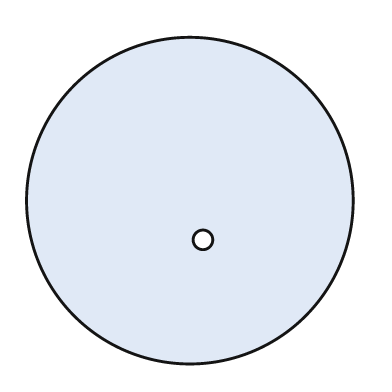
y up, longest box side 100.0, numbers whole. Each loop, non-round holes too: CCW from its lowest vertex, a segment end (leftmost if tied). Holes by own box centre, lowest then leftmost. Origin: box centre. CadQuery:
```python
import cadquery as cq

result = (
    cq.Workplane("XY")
    .moveTo(0.0, 0.0)
    .circle(50.0)
    .moveTo(4.0, -12.0)
    .circle(3.0)
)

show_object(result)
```